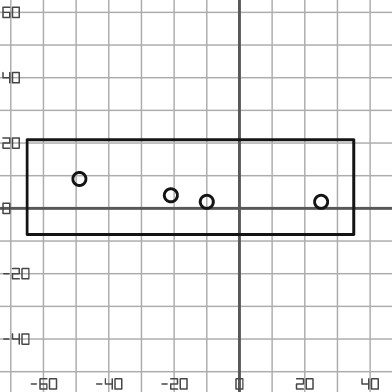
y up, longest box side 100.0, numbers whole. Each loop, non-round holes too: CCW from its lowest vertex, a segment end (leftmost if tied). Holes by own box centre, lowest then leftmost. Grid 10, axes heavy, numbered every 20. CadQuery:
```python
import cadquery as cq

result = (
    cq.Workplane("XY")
    .moveTo(-65.0, -8.0)
    .lineTo(35.0, -8.0)
    .lineTo(35.0, 21.0)
    .lineTo(-65.0, 21.0)
    .close()
    .moveTo(-10.0, 2.0)
    .circle(2.0)
    .moveTo(25.0, 2.0)
    .circle(2.0)
    .moveTo(-21.0, 4.0)
    .circle(2.0)
    .moveTo(-49.0, 9.0)
    .circle(2.0)
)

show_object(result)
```